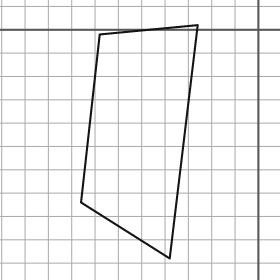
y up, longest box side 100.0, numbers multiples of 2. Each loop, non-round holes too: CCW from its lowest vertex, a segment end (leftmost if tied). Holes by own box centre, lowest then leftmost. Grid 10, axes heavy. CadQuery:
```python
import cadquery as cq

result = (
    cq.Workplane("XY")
    .moveTo(-38.0, -98.0)
    .lineTo(-26.0, 2.0)
    .lineTo(-68.0, -2.0)
    .lineTo(-76.0, -74.0)
    .close()
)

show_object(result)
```